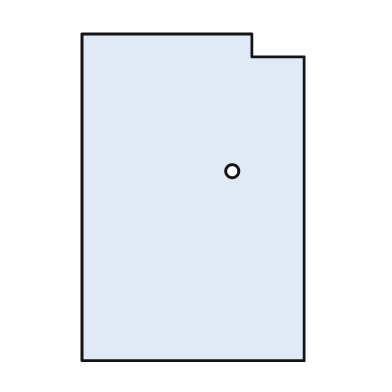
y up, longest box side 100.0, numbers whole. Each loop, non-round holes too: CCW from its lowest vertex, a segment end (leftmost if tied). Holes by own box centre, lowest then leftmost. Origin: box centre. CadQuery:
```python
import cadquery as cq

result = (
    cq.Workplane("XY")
    .moveTo(-34.0, -50.0)
    .lineTo(34.0, -50.0)
    .lineTo(34.0, 43.0)
    .lineTo(18.0, 43.0)
    .lineTo(18.0, 50.0)
    .lineTo(-34.0, 50.0)
    .close()
    .moveTo(12.0, 8.0)
    .circle(2.0)
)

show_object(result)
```